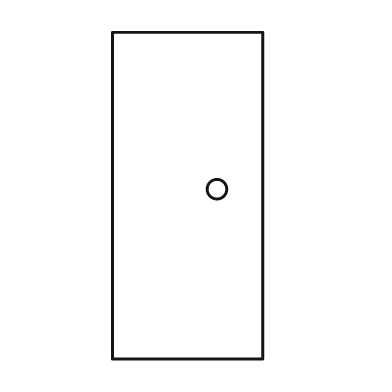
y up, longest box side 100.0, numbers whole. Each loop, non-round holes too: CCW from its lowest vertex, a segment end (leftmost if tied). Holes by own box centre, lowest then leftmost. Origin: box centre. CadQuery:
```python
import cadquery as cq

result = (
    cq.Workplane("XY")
    .moveTo(-23.0, -50.0)
    .lineTo(23.0, -50.0)
    .lineTo(23.0, 50.0)
    .lineTo(-23.0, 50.0)
    .close()
    .moveTo(9.0, 2.0)
    .circle(3.0)
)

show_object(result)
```